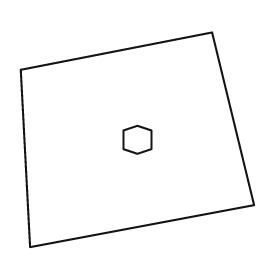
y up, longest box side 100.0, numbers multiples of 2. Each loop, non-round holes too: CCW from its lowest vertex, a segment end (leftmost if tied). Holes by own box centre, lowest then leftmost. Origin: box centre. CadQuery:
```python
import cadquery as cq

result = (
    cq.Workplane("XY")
    .moveTo(-46.0, -46.0)
    .lineTo(50.0, -28.0)
    .lineTo(32.0, 46.0)
    .lineTo(-50.0, 30.0)
    .close()
    .moveTo(0.0, -6.0)
    .lineTo(6.0, -4.0)
    .lineTo(6.0, 4.0)
    .lineTo(0.0, 6.0)
    .lineTo(-6.0, 4.0)
    .lineTo(-6.0, -4.0)
    .close()
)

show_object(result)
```